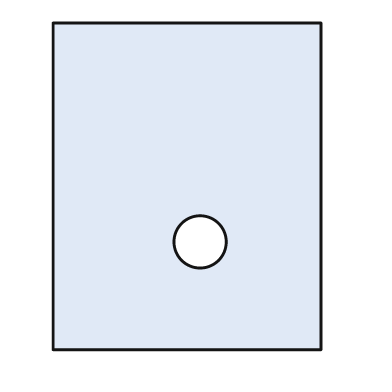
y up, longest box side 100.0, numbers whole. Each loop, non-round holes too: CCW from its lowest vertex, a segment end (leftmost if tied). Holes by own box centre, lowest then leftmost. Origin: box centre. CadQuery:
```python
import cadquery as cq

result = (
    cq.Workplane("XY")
    .moveTo(-41.0, -50.0)
    .lineTo(41.0, -50.0)
    .lineTo(41.0, 50.0)
    .lineTo(-41.0, 50.0)
    .close()
    .moveTo(4.0, -17.0)
    .circle(8.0)
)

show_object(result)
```